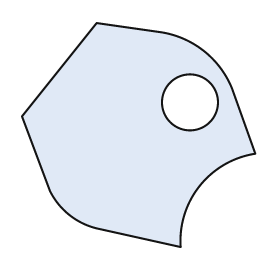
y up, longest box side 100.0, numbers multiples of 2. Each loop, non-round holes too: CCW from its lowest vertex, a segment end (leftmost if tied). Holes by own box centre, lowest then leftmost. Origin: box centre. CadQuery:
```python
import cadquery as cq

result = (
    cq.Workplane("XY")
    .moveTo(18.0, -48.0)
    .threePointArc((26.0, -22.0), (50.0, -8.0))
    .lineTo(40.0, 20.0)
    .threePointArc((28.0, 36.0), (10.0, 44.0))
    .lineTo(-18.0, 48.0)
    .lineTo(-50.0, 8.0)
    .lineTo(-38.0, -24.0)
    .threePointArc((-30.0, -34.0), (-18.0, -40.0))
    .close()
    .moveTo(22.0, 14.0)
    .circle(12.0)
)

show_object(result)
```